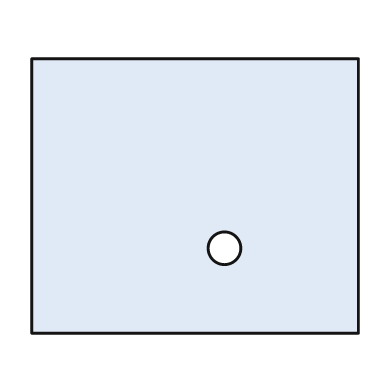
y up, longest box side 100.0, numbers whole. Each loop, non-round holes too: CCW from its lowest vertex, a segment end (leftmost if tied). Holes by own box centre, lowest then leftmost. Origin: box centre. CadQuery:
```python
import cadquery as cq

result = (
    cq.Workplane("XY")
    .moveTo(-50.0, -42.0)
    .lineTo(50.0, -42.0)
    .lineTo(50.0, 42.0)
    .lineTo(-50.0, 42.0)
    .close()
    .moveTo(9.0, -16.0)
    .circle(5.0)
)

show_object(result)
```